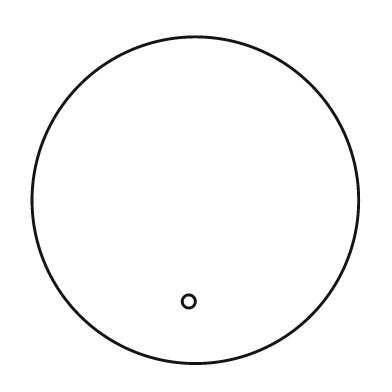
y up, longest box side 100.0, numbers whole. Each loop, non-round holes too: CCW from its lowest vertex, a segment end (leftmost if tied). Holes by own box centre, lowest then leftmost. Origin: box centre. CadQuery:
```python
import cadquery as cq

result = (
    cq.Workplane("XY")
    .moveTo(0.0, 0.0)
    .circle(50.0)
    .moveTo(-2.0, -31.0)
    .circle(2.0)
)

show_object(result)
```